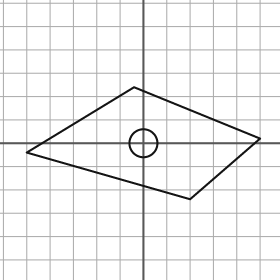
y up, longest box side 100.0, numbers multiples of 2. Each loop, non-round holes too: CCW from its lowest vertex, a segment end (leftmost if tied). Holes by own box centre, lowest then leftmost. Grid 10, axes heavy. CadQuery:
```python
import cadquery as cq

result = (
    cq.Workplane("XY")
    .moveTo(20.0, -24.0)
    .lineTo(50.0, 2.0)
    .lineTo(-4.0, 24.0)
    .lineTo(-50.0, -4.0)
    .close()
    .moveTo(0.0, 0.0)
    .circle(6.0)
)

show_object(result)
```